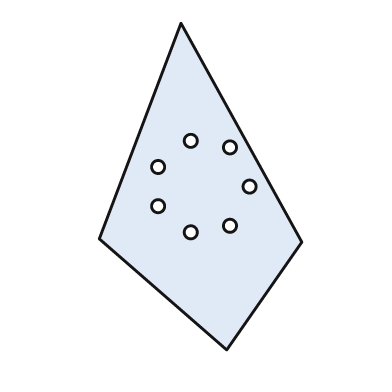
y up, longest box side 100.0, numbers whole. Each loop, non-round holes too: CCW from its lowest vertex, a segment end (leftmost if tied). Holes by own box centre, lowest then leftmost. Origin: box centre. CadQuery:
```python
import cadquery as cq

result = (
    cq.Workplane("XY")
    .moveTo(8.0, -50.0)
    .lineTo(31.0, -17.0)
    .lineTo(-6.0, 50.0)
    .lineTo(-31.0, -16.0)
    .close()
    .moveTo(-3.0, -14.0)
    .circle(2.0)
    .moveTo(9.0, -12.0)
    .circle(2.0)
    .moveTo(-13.0, -6.0)
    .circle(2.0)
    .moveTo(15.0, 0.0)
    .circle(2.0)
    .moveTo(-13.0, 6.0)
    .circle(2.0)
    .moveTo(9.0, 12.0)
    .circle(2.0)
    .moveTo(-3.0, 14.0)
    .circle(2.0)
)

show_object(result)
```